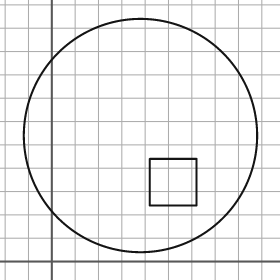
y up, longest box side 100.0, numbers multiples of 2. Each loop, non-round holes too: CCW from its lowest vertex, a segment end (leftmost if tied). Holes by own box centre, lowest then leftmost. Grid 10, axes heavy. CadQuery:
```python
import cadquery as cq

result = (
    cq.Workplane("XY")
    .moveTo(38.0, 54.0)
    .circle(50.0)
    .moveTo(42.0, 24.0)
    .lineTo(62.0, 24.0)
    .lineTo(62.0, 44.0)
    .lineTo(42.0, 44.0)
    .close()
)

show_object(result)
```